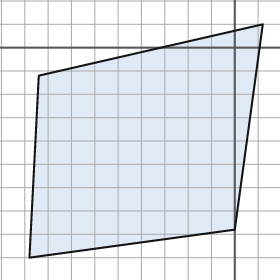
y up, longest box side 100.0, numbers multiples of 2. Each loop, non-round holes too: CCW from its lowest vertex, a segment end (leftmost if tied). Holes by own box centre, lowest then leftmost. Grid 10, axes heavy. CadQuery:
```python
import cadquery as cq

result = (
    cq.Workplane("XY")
    .moveTo(-88.0, -90.0)
    .lineTo(0.0, -78.0)
    .lineTo(12.0, 10.0)
    .lineTo(-84.0, -12.0)
    .close()
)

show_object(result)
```